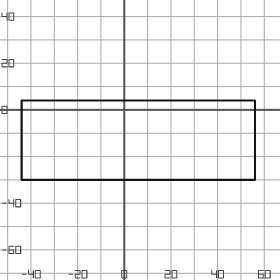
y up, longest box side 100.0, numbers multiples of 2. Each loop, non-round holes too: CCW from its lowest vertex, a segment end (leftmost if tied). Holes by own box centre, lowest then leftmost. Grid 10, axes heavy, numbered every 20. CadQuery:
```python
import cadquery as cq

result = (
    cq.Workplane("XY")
    .moveTo(-44.0, -30.0)
    .lineTo(56.0, -30.0)
    .lineTo(56.0, 4.0)
    .lineTo(-44.0, 4.0)
    .close()
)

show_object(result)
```